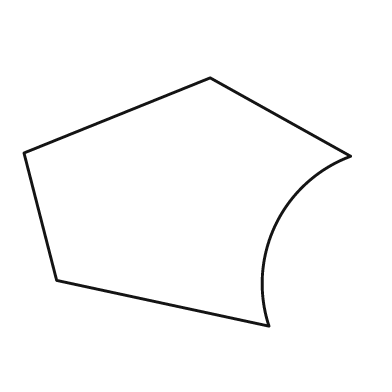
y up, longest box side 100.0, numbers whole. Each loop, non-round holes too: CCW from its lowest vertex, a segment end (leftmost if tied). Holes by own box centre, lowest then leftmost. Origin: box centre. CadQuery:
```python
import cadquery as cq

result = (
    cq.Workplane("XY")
    .moveTo(25.0, -38.0)
    .threePointArc((27.0, -7.0), (50.0, 14.0))
    .lineTo(7.0, 38.0)
    .lineTo(-50.0, 15.0)
    .lineTo(-40.0, -24.0)
    .close()
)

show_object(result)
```